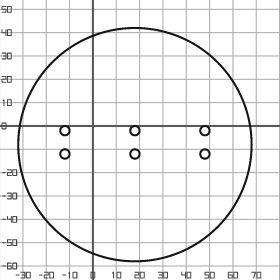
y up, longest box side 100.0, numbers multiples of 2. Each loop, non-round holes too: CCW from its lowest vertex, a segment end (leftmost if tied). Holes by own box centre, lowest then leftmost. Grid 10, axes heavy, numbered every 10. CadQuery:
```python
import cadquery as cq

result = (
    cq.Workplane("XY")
    .moveTo(18.0, -8.0)
    .circle(50.0)
    .moveTo(-12.0, -12.0)
    .circle(2.0)
    .moveTo(18.0, -12.0)
    .circle(2.0)
    .moveTo(48.0, -12.0)
    .circle(2.0)
    .moveTo(-12.0, -2.0)
    .circle(2.0)
    .moveTo(18.0, -2.0)
    .circle(2.0)
    .moveTo(48.0, -2.0)
    .circle(2.0)
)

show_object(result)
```